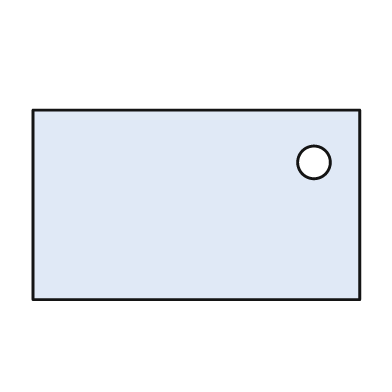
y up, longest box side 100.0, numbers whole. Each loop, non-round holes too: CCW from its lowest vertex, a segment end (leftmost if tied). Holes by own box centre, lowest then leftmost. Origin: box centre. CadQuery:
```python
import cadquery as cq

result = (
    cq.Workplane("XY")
    .moveTo(-50.0, -29.0)
    .lineTo(50.0, -29.0)
    .lineTo(50.0, 29.0)
    .lineTo(-50.0, 29.0)
    .close()
    .moveTo(36.0, 13.0)
    .circle(5.0)
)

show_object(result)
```